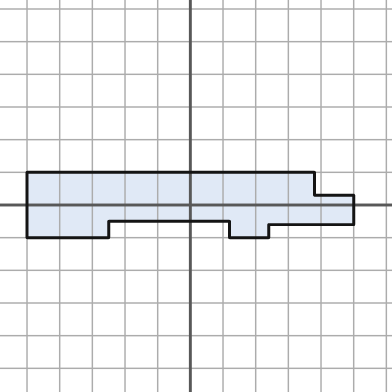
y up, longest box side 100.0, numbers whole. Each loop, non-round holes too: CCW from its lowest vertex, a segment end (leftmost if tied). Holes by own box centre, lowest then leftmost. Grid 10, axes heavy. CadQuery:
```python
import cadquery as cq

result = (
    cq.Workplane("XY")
    .moveTo(-50.0, -10.0)
    .lineTo(-25.0, -10.0)
    .lineTo(-25.0, -5.0)
    .lineTo(12.0, -5.0)
    .lineTo(12.0, -10.0)
    .lineTo(24.0, -10.0)
    .lineTo(24.0, -6.0)
    .lineTo(50.0, -6.0)
    .lineTo(50.0, 3.0)
    .lineTo(38.0, 3.0)
    .lineTo(38.0, 10.0)
    .lineTo(-50.0, 10.0)
    .close()
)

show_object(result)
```